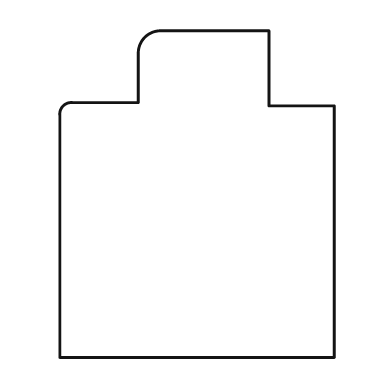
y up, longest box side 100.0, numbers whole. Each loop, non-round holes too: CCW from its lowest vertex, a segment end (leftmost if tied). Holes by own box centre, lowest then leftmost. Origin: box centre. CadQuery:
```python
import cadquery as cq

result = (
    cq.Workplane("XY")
    .moveTo(-42.0, -50.0)
    .lineTo(42.0, -50.0)
    .lineTo(42.0, 27.0)
    .lineTo(22.0, 27.0)
    .lineTo(22.0, 50.0)
    .lineTo(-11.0, 50.0)
    .threePointArc((-16.0, 48.0), (-18.0, 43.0))
    .lineTo(-18.0, 28.0)
    .lineTo(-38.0, 28.0)
    .threePointArc((-41.0, 27.0), (-42.0, 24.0))
    .close()
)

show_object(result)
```